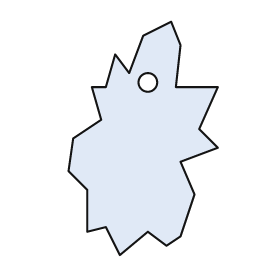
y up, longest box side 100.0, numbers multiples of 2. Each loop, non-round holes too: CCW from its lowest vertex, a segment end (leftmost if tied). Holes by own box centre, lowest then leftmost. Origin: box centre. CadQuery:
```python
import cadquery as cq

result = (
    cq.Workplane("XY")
    .moveTo(-10.0, -50.0)
    .lineTo(2.0, -40.0)
    .lineTo(10.0, -46.0)
    .lineTo(16.0, -42.0)
    .lineTo(22.0, -24.0)
    .lineTo(16.0, -10.0)
    .lineTo(32.0, -4.0)
    .lineTo(24.0, 4.0)
    .lineTo(32.0, 22.0)
    .lineTo(14.0, 22.0)
    .lineTo(16.0, 40.0)
    .lineTo(12.0, 50.0)
    .lineTo(0.0, 44.0)
    .lineTo(-6.0, 28.0)
    .lineTo(-12.0, 36.0)
    .lineTo(-16.0, 22.0)
    .lineTo(-22.0, 22.0)
    .lineTo(-18.0, 8.0)
    .lineTo(-30.0, 0.0)
    .lineTo(-32.0, -14.0)
    .lineTo(-24.0, -22.0)
    .lineTo(-24.0, -40.0)
    .lineTo(-16.0, -38.0)
    .close()
    .moveTo(2.0, 24.0)
    .circle(4.0)
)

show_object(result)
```